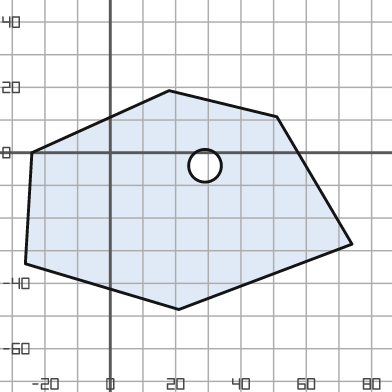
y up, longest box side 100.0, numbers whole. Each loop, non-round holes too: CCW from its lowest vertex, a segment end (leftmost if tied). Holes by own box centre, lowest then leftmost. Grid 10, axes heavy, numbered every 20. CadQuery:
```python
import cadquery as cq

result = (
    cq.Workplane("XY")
    .moveTo(21.0, -48.0)
    .lineTo(74.0, -28.0)
    .lineTo(51.0, 11.0)
    .lineTo(18.0, 19.0)
    .lineTo(-24.0, 0.0)
    .lineTo(-26.0, -34.0)
    .close()
    .moveTo(29.0, -4.0)
    .circle(5.0)
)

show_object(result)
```